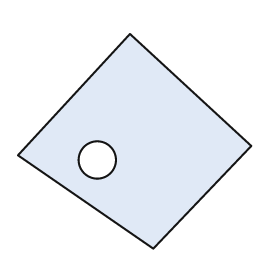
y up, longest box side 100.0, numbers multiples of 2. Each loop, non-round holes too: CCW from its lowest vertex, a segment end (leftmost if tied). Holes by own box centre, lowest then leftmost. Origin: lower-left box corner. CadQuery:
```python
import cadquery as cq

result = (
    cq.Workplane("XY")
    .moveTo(58.0, 0.0)
    .lineTo(100.0, 44.0)
    .lineTo(48.0, 92.0)
    .lineTo(0.0, 40.0)
    .close()
    .moveTo(34.0, 38.0)
    .circle(8.0)
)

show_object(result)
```